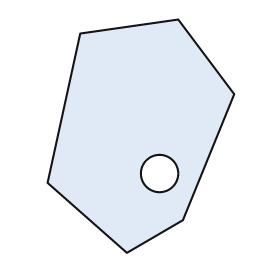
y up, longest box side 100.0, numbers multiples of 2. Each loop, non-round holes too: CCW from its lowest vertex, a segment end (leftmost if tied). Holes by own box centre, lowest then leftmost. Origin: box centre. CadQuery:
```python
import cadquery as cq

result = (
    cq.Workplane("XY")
    .moveTo(-6.0, -50.0)
    .lineTo(18.0, -36.0)
    .lineTo(40.0, 18.0)
    .lineTo(16.0, 50.0)
    .lineTo(-26.0, 44.0)
    .lineTo(-40.0, -20.0)
    .close()
    .moveTo(8.0, -16.0)
    .circle(8.0)
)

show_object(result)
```